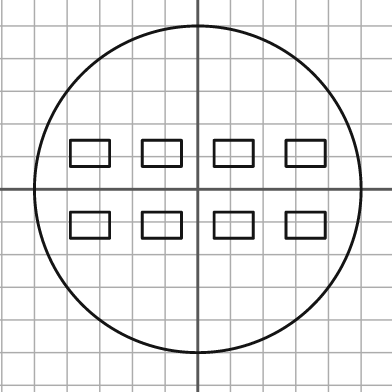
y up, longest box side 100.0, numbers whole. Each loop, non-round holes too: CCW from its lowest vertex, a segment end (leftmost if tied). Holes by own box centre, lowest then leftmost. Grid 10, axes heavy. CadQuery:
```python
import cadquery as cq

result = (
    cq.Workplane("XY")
    .moveTo(0.0, 0.0)
    .circle(50.0)
    .moveTo(-39.0, -15.0)
    .lineTo(-27.0, -15.0)
    .lineTo(-27.0, -7.0)
    .lineTo(-39.0, -7.0)
    .close()
    .moveTo(-17.0, -15.0)
    .lineTo(-5.0, -15.0)
    .lineTo(-5.0, -7.0)
    .lineTo(-17.0, -7.0)
    .close()
    .moveTo(5.0, -15.0)
    .lineTo(17.0, -15.0)
    .lineTo(17.0, -7.0)
    .lineTo(5.0, -7.0)
    .close()
    .moveTo(27.0, -15.0)
    .lineTo(39.0, -15.0)
    .lineTo(39.0, -7.0)
    .lineTo(27.0, -7.0)
    .close()
    .moveTo(-39.0, 7.0)
    .lineTo(-27.0, 7.0)
    .lineTo(-27.0, 15.0)
    .lineTo(-39.0, 15.0)
    .close()
    .moveTo(-17.0, 7.0)
    .lineTo(-5.0, 7.0)
    .lineTo(-5.0, 15.0)
    .lineTo(-17.0, 15.0)
    .close()
    .moveTo(5.0, 7.0)
    .lineTo(17.0, 7.0)
    .lineTo(17.0, 15.0)
    .lineTo(5.0, 15.0)
    .close()
    .moveTo(27.0, 7.0)
    .lineTo(39.0, 7.0)
    .lineTo(39.0, 15.0)
    .lineTo(27.0, 15.0)
    .close()
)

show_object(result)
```